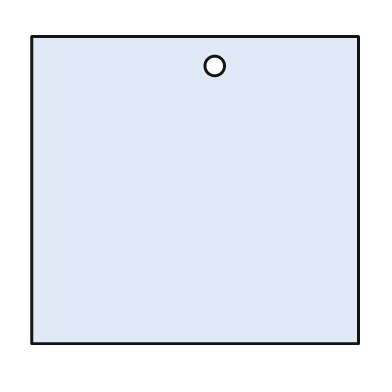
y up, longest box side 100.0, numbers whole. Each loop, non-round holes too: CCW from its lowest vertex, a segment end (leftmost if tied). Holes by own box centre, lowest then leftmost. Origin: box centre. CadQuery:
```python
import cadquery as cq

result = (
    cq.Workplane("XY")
    .moveTo(-50.0, -47.0)
    .lineTo(50.0, -47.0)
    .lineTo(50.0, 47.0)
    .lineTo(-50.0, 47.0)
    .close()
    .moveTo(6.0, 38.0)
    .circle(3.0)
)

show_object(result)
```